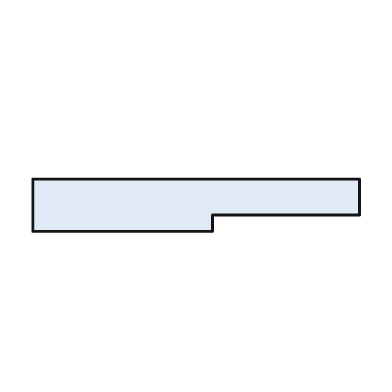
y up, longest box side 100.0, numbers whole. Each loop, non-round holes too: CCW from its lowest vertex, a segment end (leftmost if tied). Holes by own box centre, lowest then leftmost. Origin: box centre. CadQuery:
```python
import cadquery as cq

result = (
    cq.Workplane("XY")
    .moveTo(-50.0, -8.0)
    .lineTo(5.0, -8.0)
    .lineTo(5.0, -3.0)
    .lineTo(50.0, -3.0)
    .lineTo(50.0, 8.0)
    .lineTo(-50.0, 8.0)
    .close()
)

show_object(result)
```